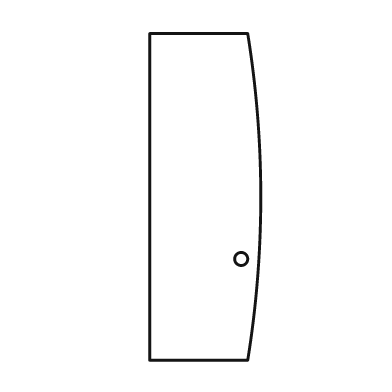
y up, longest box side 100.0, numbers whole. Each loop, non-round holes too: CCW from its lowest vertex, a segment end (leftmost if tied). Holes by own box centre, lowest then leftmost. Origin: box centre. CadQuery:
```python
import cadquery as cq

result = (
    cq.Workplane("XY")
    .moveTo(-17.0, -50.0)
    .lineTo(13.0, -50.0)
    .threePointArc((17.0, 0.0), (13.0, 50.0))
    .lineTo(-17.0, 50.0)
    .close()
    .moveTo(11.0, -19.0)
    .circle(2.0)
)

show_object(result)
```